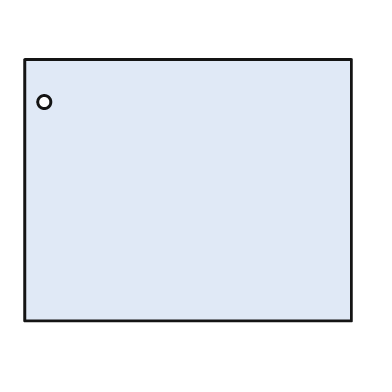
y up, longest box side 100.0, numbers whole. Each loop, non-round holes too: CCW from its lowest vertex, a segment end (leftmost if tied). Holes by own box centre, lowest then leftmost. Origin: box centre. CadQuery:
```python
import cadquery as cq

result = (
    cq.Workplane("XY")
    .moveTo(-50.0, -40.0)
    .lineTo(50.0, -40.0)
    .lineTo(50.0, 40.0)
    .lineTo(-50.0, 40.0)
    .close()
    .moveTo(-44.0, 27.0)
    .circle(2.0)
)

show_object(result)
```